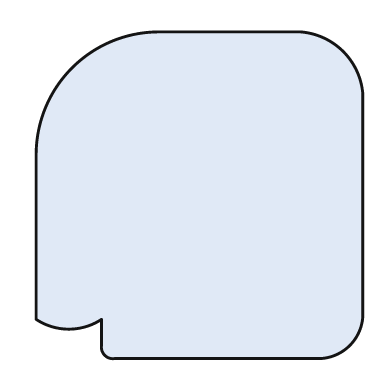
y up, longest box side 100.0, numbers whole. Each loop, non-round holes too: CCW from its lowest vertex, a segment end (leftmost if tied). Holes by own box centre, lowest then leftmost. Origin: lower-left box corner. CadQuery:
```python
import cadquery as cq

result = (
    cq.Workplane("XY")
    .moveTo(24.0, 0.0)
    .lineTo(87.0, 0.0)
    .threePointArc((96.0, 4.0), (100.0, 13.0))
    .lineTo(100.0, 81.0)
    .threePointArc((94.0, 94.0), (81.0, 100.0))
    .lineTo(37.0, 100.0)
    .threePointArc((11.0, 89.0), (0.0, 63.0))
    .lineTo(0.0, 12.0)
    .threePointArc((10.0, 9.0), (20.0, 12.0))
    .lineTo(20.0, 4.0)
    .threePointArc((21.0, 1.0), (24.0, 0.0))
    .close()
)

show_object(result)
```